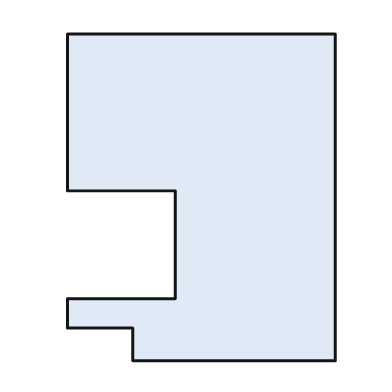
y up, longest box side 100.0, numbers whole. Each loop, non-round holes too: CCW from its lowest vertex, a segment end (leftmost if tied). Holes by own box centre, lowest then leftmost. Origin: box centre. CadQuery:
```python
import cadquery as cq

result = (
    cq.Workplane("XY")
    .moveTo(-21.0, -50.0)
    .lineTo(41.0, -50.0)
    .lineTo(41.0, 50.0)
    .lineTo(-41.0, 50.0)
    .lineTo(-41.0, 2.0)
    .lineTo(-8.0, 2.0)
    .lineTo(-8.0, -31.0)
    .lineTo(-41.0, -31.0)
    .lineTo(-41.0, -40.0)
    .lineTo(-21.0, -40.0)
    .close()
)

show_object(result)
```